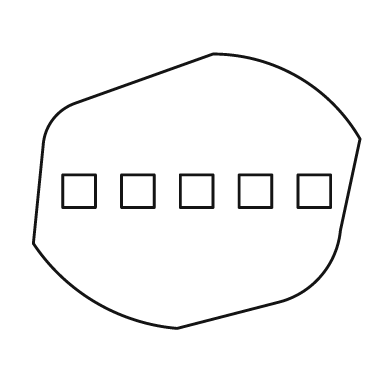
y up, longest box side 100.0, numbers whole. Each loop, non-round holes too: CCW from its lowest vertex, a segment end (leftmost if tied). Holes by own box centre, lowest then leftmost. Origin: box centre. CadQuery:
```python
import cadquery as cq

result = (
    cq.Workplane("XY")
    .moveTo(-6.0, -42.0)
    .lineTo(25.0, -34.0)
    .threePointArc((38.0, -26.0), (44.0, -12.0))
    .lineTo(50.0, 16.0)
    .threePointArc((31.0, 35.0), (5.0, 42.0))
    .lineTo(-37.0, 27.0)
    .threePointArc((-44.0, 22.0), (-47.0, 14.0))
    .lineTo(-50.0, -16.0)
    .threePointArc((-31.0, -34.0), (-6.0, -42.0))
    .close()
    .moveTo(-41.0, -5.0)
    .lineTo(-31.0, -5.0)
    .lineTo(-31.0, 5.0)
    .lineTo(-41.0, 5.0)
    .close()
    .moveTo(-23.0, -5.0)
    .lineTo(-13.0, -5.0)
    .lineTo(-13.0, 5.0)
    .lineTo(-23.0, 5.0)
    .close()
    .moveTo(-5.0, -5.0)
    .lineTo(5.0, -5.0)
    .lineTo(5.0, 5.0)
    .lineTo(-5.0, 5.0)
    .close()
    .moveTo(13.0, -5.0)
    .lineTo(23.0, -5.0)
    .lineTo(23.0, 5.0)
    .lineTo(13.0, 5.0)
    .close()
    .moveTo(31.0, -5.0)
    .lineTo(41.0, -5.0)
    .lineTo(41.0, 5.0)
    .lineTo(31.0, 5.0)
    .close()
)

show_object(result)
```